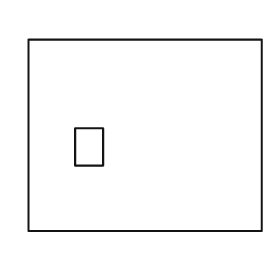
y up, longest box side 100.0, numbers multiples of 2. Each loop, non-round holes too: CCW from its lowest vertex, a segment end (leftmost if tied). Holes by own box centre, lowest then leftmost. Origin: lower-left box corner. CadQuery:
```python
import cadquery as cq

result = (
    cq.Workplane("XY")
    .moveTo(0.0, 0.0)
    .lineTo(100.0, 0.0)
    .lineTo(100.0, 82.0)
    .lineTo(0.0, 82.0)
    .close()
    .moveTo(20.0, 28.0)
    .lineTo(32.0, 28.0)
    .lineTo(32.0, 44.0)
    .lineTo(20.0, 44.0)
    .close()
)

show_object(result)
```